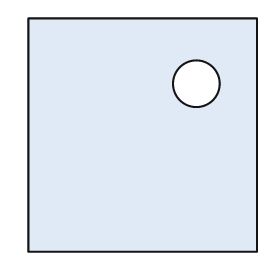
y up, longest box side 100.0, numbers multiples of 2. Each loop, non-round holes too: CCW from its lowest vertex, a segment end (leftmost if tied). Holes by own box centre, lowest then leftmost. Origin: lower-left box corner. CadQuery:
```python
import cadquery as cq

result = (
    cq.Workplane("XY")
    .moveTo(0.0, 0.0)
    .lineTo(98.0, 0.0)
    .lineTo(98.0, 100.0)
    .lineTo(0.0, 100.0)
    .close()
    .moveTo(72.0, 72.0)
    .circle(10.0)
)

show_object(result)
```